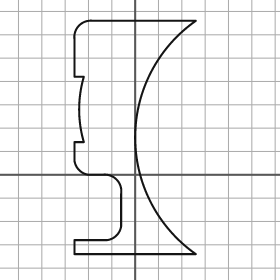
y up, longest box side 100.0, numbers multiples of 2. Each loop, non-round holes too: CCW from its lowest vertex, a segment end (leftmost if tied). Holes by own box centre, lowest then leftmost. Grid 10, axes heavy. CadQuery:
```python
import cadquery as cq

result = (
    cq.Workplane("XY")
    .moveTo(-26.0, -34.0)
    .lineTo(26.0, -34.0)
    .threePointArc((0.0, 16.0), (26.0, 66.0))
    .lineTo(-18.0, 66.0)
    .threePointArc((-24.0, 64.0), (-26.0, 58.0))
    .lineTo(-26.0, 42.0)
    .lineTo(-22.0, 42.0)
    .threePointArc((-24.0, 28.0), (-22.0, 14.0))
    .lineTo(-26.0, 14.0)
    .lineTo(-26.0, 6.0)
    .threePointArc((-24.0, 2.0), (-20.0, 0.0))
    .lineTo(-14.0, 0.0)
    .threePointArc((-8.0, -2.0), (-6.0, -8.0))
    .lineTo(-6.0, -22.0)
    .threePointArc((-8.0, -26.0), (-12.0, -28.0))
    .lineTo(-26.0, -28.0)
    .close()
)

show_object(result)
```